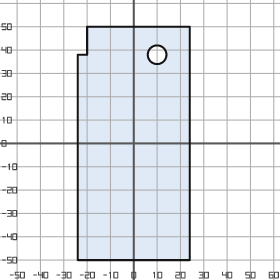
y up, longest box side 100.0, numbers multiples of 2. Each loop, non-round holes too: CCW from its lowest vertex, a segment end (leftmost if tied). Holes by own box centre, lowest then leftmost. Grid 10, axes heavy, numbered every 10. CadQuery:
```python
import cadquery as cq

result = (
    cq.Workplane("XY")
    .moveTo(-24.0, -50.0)
    .lineTo(24.0, -50.0)
    .lineTo(24.0, 50.0)
    .lineTo(-20.0, 50.0)
    .lineTo(-20.0, 38.0)
    .lineTo(-24.0, 38.0)
    .close()
    .moveTo(10.0, 38.0)
    .circle(4.0)
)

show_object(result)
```